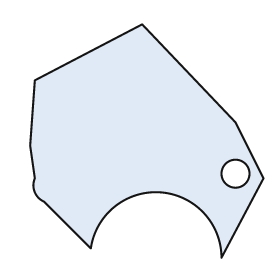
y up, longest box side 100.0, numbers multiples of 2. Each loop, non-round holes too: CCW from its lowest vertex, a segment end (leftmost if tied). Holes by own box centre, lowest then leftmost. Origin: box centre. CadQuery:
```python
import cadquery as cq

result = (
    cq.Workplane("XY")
    .moveTo(32.0, -50.0)
    .lineTo(50.0, -16.0)
    .lineTo(38.0, 8.0)
    .lineTo(-2.0, 50.0)
    .lineTo(-48.0, 26.0)
    .lineTo(-50.0, -2.0)
    .lineTo(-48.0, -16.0)
    .threePointArc((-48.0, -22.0), (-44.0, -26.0))
    .lineTo(-24.0, -46.0)
    .threePointArc((6.0, -22.0), (32.0, -50.0))
    .close()
    .moveTo(38.0, -14.0)
    .circle(6.0)
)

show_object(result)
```